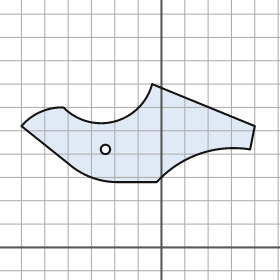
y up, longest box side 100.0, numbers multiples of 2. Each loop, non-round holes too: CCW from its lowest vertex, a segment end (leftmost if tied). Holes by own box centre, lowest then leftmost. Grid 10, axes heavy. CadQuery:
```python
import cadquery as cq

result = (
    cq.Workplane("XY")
    .moveTo(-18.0, 28.0)
    .lineTo(-2.0, 28.0)
    .threePointArc((16.0, 40.0), (38.0, 42.0))
    .lineTo(40.0, 52.0)
    .lineTo(-4.0, 70.0)
    .threePointArc((-20.0, 54.0), (-42.0, 60.0))
    .threePointArc((-52.0, 58.0), (-60.0, 52.0))
    .lineTo(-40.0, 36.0)
    .threePointArc((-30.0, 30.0), (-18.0, 28.0))
    .close()
    .moveTo(-24.0, 42.0)
    .circle(2.0)
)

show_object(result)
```